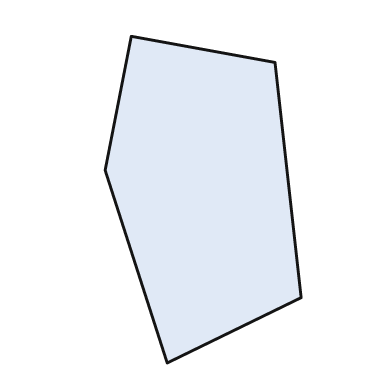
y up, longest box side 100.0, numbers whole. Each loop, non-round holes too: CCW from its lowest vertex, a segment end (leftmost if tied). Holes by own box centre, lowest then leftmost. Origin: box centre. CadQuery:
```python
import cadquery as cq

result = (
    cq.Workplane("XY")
    .moveTo(-11.0, -50.0)
    .lineTo(30.0, -30.0)
    .lineTo(22.0, 42.0)
    .lineTo(-22.0, 50.0)
    .lineTo(-30.0, 9.0)
    .close()
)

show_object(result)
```